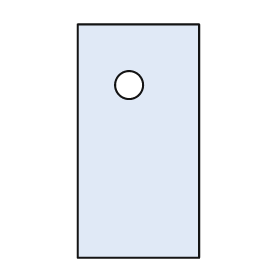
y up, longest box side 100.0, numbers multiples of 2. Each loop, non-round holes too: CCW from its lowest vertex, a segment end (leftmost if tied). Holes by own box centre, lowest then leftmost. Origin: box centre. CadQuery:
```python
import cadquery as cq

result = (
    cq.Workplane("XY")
    .moveTo(-26.0, -50.0)
    .lineTo(26.0, -50.0)
    .lineTo(26.0, 50.0)
    .lineTo(-26.0, 50.0)
    .close()
    .moveTo(-4.0, 24.0)
    .circle(6.0)
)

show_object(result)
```